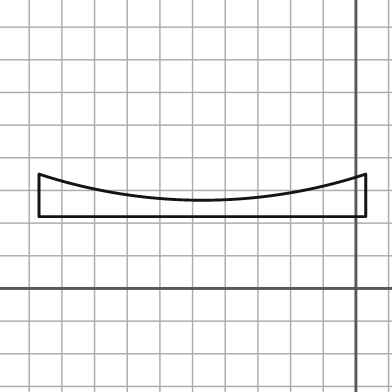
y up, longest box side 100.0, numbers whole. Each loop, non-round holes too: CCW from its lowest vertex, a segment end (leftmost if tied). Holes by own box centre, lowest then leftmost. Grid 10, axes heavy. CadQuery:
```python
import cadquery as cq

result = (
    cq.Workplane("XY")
    .moveTo(-97.0, 22.0)
    .lineTo(3.0, 22.0)
    .lineTo(3.0, 35.0)
    .threePointArc((-47.0, 27.0), (-97.0, 35.0))
    .close()
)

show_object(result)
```